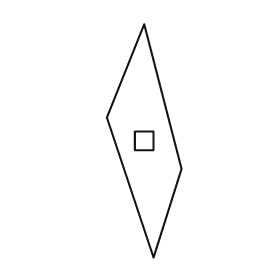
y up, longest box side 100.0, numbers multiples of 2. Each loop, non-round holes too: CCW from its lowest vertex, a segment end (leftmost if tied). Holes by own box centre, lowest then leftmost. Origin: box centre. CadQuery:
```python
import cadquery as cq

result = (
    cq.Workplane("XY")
    .moveTo(4.0, -50.0)
    .lineTo(16.0, -12.0)
    .lineTo(0.0, 50.0)
    .lineTo(-16.0, 10.0)
    .close()
    .moveTo(-4.0, -4.0)
    .lineTo(4.0, -4.0)
    .lineTo(4.0, 4.0)
    .lineTo(-4.0, 4.0)
    .close()
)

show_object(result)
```